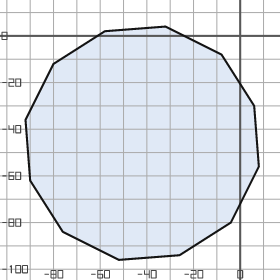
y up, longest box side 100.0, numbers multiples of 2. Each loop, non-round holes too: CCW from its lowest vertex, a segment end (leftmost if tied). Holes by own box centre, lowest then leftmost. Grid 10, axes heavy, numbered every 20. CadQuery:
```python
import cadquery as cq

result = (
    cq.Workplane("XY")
    .moveTo(-52.0, -96.0)
    .lineTo(-26.0, -94.0)
    .lineTo(-4.0, -80.0)
    .lineTo(8.0, -56.0)
    .lineTo(6.0, -30.0)
    .lineTo(-8.0, -8.0)
    .lineTo(-32.0, 4.0)
    .lineTo(-58.0, 2.0)
    .lineTo(-80.0, -12.0)
    .lineTo(-92.0, -36.0)
    .lineTo(-90.0, -62.0)
    .lineTo(-76.0, -84.0)
    .close()
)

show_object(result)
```